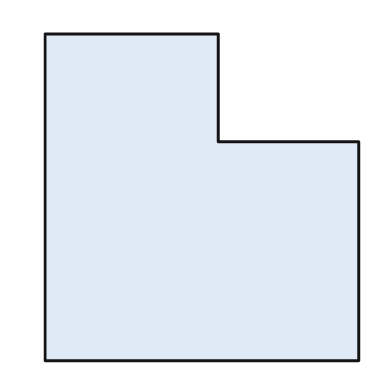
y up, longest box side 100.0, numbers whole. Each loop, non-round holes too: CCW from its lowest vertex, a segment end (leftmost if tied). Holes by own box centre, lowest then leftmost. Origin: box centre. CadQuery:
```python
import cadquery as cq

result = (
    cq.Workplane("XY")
    .moveTo(-48.0, -50.0)
    .lineTo(48.0, -50.0)
    .lineTo(48.0, 17.0)
    .lineTo(5.0, 17.0)
    .lineTo(5.0, 50.0)
    .lineTo(-48.0, 50.0)
    .close()
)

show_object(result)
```